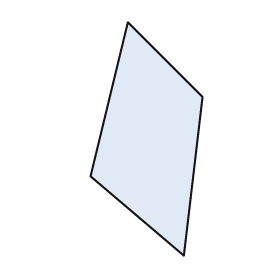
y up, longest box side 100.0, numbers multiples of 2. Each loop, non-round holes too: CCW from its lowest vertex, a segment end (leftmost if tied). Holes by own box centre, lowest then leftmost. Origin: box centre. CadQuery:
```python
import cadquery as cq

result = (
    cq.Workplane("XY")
    .moveTo(16.0, -50.0)
    .lineTo(24.0, 18.0)
    .lineTo(-8.0, 50.0)
    .lineTo(-24.0, -16.0)
    .close()
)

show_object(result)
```